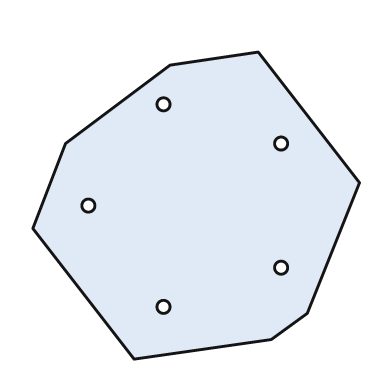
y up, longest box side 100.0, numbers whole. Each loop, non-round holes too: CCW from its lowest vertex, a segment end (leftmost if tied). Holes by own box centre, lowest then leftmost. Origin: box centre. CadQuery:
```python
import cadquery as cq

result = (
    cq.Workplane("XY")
    .moveTo(-19.0, -47.0)
    .lineTo(23.0, -41.0)
    .lineTo(34.0, -33.0)
    .lineTo(50.0, 7.0)
    .lineTo(19.0, 47.0)
    .lineTo(-8.0, 43.0)
    .lineTo(-40.0, 19.0)
    .lineTo(-50.0, -7.0)
    .close()
    .moveTo(-10.0, -31.0)
    .circle(2.0)
    .moveTo(26.0, -19.0)
    .circle(2.0)
    .moveTo(-33.0, 0.0)
    .circle(2.0)
    .moveTo(26.0, 19.0)
    .circle(2.0)
    .moveTo(-10.0, 31.0)
    .circle(2.0)
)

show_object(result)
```